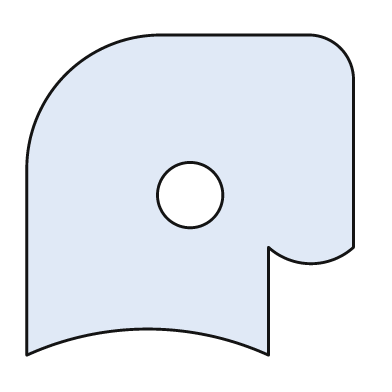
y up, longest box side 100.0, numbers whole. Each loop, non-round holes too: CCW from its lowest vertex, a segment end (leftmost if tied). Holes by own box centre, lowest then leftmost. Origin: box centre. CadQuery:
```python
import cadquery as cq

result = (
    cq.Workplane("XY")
    .moveTo(-50.0, -49.0)
    .threePointArc((-13.0, -41.0), (24.0, -49.0))
    .lineTo(24.0, -16.0)
    .threePointArc((37.0, -21.0), (50.0, -16.0))
    .lineTo(50.0, 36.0)
    .threePointArc((46.0, 45.0), (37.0, 49.0))
    .lineTo(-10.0, 49.0)
    .threePointArc((-38.0, 37.0), (-50.0, 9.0))
    .close()
    .moveTo(0.0, 0.0)
    .circle(10.0)
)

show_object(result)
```